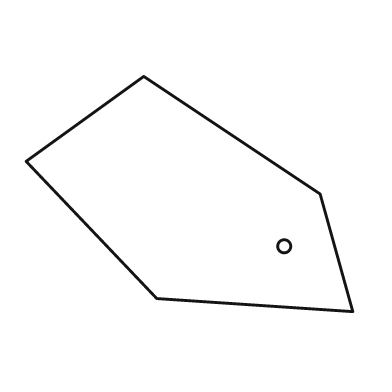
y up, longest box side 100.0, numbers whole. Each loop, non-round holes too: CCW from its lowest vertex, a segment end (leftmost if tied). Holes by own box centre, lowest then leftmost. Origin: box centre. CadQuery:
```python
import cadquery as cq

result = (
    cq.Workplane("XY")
    .moveTo(50.0, -36.0)
    .lineTo(40.0, 0.0)
    .lineTo(-14.0, 36.0)
    .lineTo(-50.0, 10.0)
    .lineTo(-10.0, -32.0)
    .close()
    .moveTo(29.0, -16.0)
    .circle(2.0)
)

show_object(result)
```